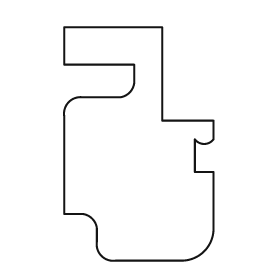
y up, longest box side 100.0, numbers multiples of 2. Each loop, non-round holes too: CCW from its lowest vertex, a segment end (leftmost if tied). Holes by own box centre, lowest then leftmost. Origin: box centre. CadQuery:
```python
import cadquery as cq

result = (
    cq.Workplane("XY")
    .moveTo(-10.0, -50.0)
    .lineTo(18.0, -50.0)
    .threePointArc((28.0, -46.0), (32.0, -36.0))
    .lineTo(32.0, -12.0)
    .lineTo(24.0, -12.0)
    .lineTo(24.0, 2.0)
    .threePointArc((28.0, 0.0), (32.0, 2.0))
    .lineTo(32.0, 10.0)
    .lineTo(10.0, 10.0)
    .lineTo(10.0, 50.0)
    .lineTo(-32.0, 50.0)
    .lineTo(-32.0, 34.0)
    .lineTo(-2.0, 34.0)
    .lineTo(-2.0, 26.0)
    .threePointArc((-4.0, 22.0), (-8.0, 20.0))
    .lineTo(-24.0, 20.0)
    .threePointArc((-30.0, 18.0), (-32.0, 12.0))
    .lineTo(-32.0, -30.0)
    .lineTo(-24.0, -30.0)
    .threePointArc((-20.0, -32.0), (-18.0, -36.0))
    .lineTo(-18.0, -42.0)
    .threePointArc((-16.0, -48.0), (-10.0, -50.0))
    .close()
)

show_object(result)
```